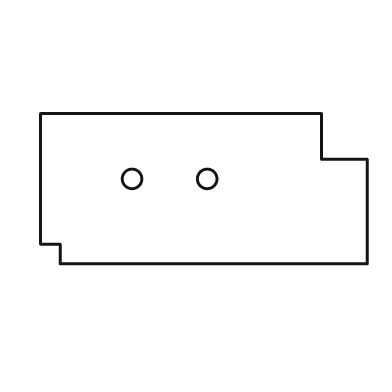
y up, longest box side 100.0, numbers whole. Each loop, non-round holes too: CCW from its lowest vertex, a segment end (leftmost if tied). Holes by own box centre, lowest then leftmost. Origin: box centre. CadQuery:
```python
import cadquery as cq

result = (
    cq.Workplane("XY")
    .moveTo(-44.0, -23.0)
    .lineTo(50.0, -23.0)
    .lineTo(50.0, 9.0)
    .lineTo(36.0, 9.0)
    .lineTo(36.0, 23.0)
    .lineTo(-50.0, 23.0)
    .lineTo(-50.0, -17.0)
    .lineTo(-44.0, -17.0)
    .close()
    .moveTo(-22.0, 3.0)
    .circle(3.0)
    .moveTo(1.0, 3.0)
    .circle(3.0)
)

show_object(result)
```